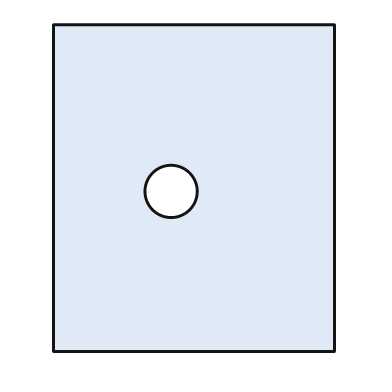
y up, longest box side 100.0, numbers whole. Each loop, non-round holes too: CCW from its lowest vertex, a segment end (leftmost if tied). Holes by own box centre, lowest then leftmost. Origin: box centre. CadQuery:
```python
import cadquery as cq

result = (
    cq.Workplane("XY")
    .moveTo(-43.0, -50.0)
    .lineTo(43.0, -50.0)
    .lineTo(43.0, 50.0)
    .lineTo(-43.0, 50.0)
    .close()
    .moveTo(-7.0, -1.0)
    .circle(8.0)
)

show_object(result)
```